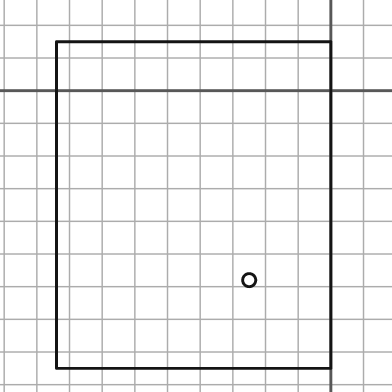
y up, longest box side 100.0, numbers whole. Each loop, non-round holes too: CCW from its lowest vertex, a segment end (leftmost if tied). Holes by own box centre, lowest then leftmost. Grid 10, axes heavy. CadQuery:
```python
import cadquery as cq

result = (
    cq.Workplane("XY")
    .moveTo(-84.0, -85.0)
    .lineTo(0.0, -85.0)
    .lineTo(0.0, 15.0)
    .lineTo(-84.0, 15.0)
    .close()
    .moveTo(-25.0, -58.0)
    .circle(2.0)
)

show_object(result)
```